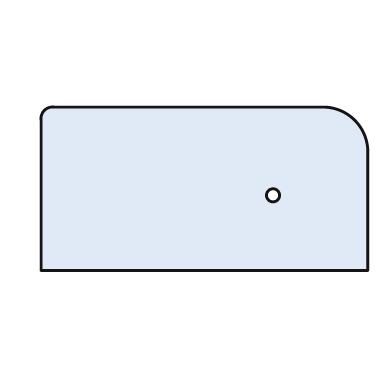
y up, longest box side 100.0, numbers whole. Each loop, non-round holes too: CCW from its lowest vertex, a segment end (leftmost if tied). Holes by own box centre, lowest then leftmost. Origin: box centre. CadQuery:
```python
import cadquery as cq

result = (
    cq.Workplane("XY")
    .moveTo(-50.0, -25.0)
    .lineTo(50.0, -25.0)
    .lineTo(50.0, 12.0)
    .threePointArc((46.0, 21.0), (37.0, 25.0))
    .lineTo(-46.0, 25.0)
    .threePointArc((-49.0, 24.0), (-50.0, 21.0))
    .close()
    .moveTo(21.0, -2.0)
    .circle(2.0)
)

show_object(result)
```